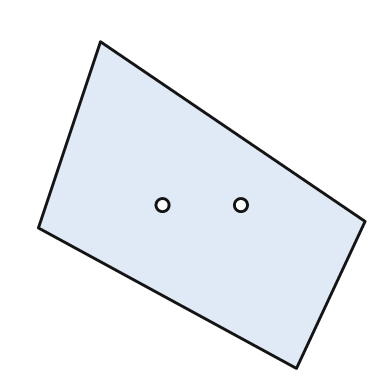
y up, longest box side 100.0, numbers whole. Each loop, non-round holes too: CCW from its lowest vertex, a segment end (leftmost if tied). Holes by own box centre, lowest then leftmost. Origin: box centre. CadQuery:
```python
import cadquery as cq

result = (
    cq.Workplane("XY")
    .moveTo(29.0, -50.0)
    .lineTo(50.0, -5.0)
    .lineTo(-31.0, 50.0)
    .lineTo(-50.0, -7.0)
    .close()
    .moveTo(-12.0, 0.0)
    .circle(2.0)
    .moveTo(12.0, 0.0)
    .circle(2.0)
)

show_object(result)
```